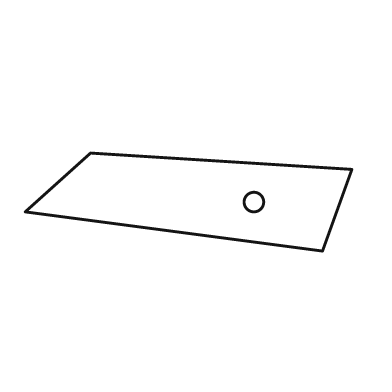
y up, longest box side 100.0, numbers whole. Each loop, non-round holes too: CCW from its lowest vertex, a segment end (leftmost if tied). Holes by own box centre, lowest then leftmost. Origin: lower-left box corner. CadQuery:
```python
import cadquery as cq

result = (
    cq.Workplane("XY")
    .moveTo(91.0, 0.0)
    .lineTo(100.0, 25.0)
    .lineTo(20.0, 30.0)
    .lineTo(0.0, 12.0)
    .close()
    .moveTo(70.0, 15.0)
    .circle(3.0)
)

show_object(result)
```